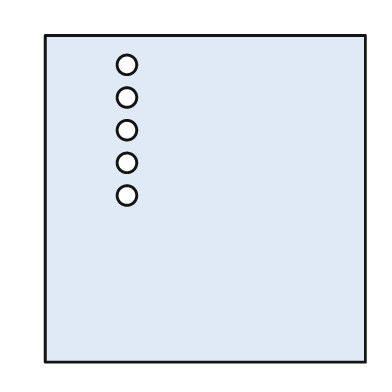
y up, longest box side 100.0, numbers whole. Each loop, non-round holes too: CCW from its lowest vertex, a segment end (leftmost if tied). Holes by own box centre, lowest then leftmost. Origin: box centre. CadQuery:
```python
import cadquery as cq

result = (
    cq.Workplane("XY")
    .moveTo(-49.0, -50.0)
    .lineTo(49.0, -50.0)
    .lineTo(49.0, 50.0)
    .lineTo(-49.0, 50.0)
    .close()
    .moveTo(-24.0, 1.0)
    .circle(3.0)
    .moveTo(-24.0, 11.0)
    .circle(3.0)
    .moveTo(-24.0, 21.0)
    .circle(3.0)
    .moveTo(-24.0, 31.0)
    .circle(3.0)
    .moveTo(-24.0, 41.0)
    .circle(3.0)
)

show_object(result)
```